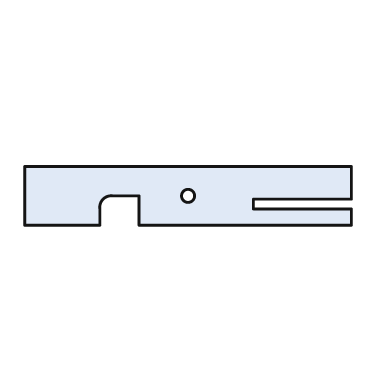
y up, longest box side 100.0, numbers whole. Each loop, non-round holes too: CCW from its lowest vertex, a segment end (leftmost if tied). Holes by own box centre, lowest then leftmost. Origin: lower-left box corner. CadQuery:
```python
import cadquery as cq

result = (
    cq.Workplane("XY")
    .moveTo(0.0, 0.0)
    .lineTo(23.0, 0.0)
    .lineTo(23.0, 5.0)
    .threePointArc((24.0, 8.0), (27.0, 9.0))
    .lineTo(35.0, 9.0)
    .lineTo(35.0, 0.0)
    .lineTo(100.0, 0.0)
    .lineTo(100.0, 5.0)
    .lineTo(70.0, 5.0)
    .lineTo(70.0, 8.0)
    .lineTo(100.0, 8.0)
    .lineTo(100.0, 18.0)
    .lineTo(0.0, 18.0)
    .close()
    .moveTo(50.0, 9.0)
    .circle(2.0)
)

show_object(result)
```